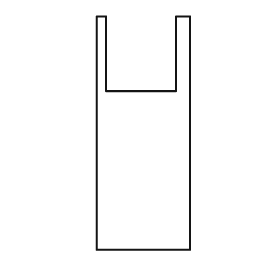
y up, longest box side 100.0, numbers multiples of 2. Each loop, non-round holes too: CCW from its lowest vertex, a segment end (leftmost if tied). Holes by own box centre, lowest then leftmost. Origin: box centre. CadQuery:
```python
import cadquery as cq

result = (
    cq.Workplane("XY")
    .moveTo(-20.0, -50.0)
    .lineTo(20.0, -50.0)
    .lineTo(20.0, 50.0)
    .lineTo(14.0, 50.0)
    .lineTo(14.0, 18.0)
    .lineTo(-16.0, 18.0)
    .lineTo(-16.0, 50.0)
    .lineTo(-20.0, 50.0)
    .close()
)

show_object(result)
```